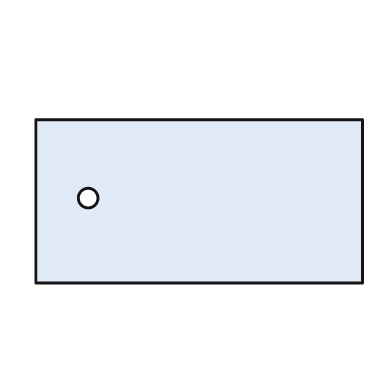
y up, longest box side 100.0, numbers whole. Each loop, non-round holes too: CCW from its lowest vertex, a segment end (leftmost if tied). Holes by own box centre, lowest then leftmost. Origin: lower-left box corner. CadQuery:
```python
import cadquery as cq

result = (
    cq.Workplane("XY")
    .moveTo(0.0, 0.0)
    .lineTo(100.0, 0.0)
    .lineTo(100.0, 50.0)
    .lineTo(0.0, 50.0)
    .close()
    .moveTo(16.0, 26.0)
    .circle(3.0)
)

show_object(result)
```